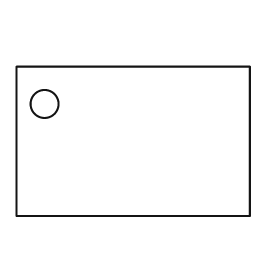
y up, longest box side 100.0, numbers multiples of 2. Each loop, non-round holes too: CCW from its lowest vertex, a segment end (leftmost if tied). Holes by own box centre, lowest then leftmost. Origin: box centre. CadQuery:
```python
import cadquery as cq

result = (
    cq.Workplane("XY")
    .moveTo(-50.0, -32.0)
    .lineTo(50.0, -32.0)
    .lineTo(50.0, 32.0)
    .lineTo(-50.0, 32.0)
    .close()
    .moveTo(-38.0, 16.0)
    .circle(6.0)
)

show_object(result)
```